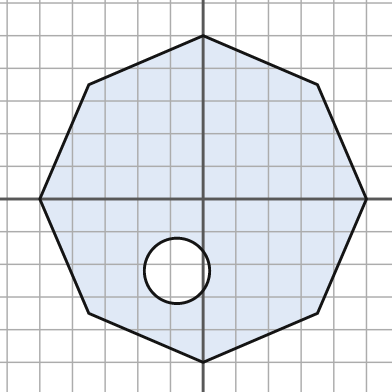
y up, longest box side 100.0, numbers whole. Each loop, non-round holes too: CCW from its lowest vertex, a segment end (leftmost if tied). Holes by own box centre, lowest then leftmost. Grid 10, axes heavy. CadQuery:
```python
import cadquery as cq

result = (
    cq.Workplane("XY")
    .moveTo(0.0, -50.0)
    .lineTo(35.0, -35.0)
    .lineTo(50.0, 0.0)
    .lineTo(35.0, 35.0)
    .lineTo(0.0, 50.0)
    .lineTo(-35.0, 35.0)
    .lineTo(-50.0, 0.0)
    .lineTo(-35.0, -35.0)
    .close()
    .moveTo(-8.0, -22.0)
    .circle(10.0)
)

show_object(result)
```